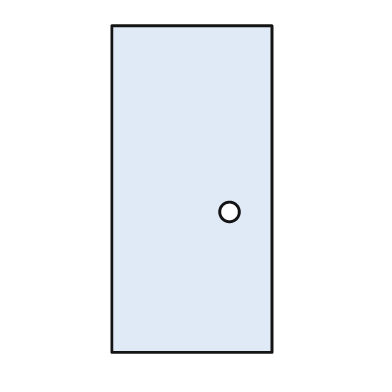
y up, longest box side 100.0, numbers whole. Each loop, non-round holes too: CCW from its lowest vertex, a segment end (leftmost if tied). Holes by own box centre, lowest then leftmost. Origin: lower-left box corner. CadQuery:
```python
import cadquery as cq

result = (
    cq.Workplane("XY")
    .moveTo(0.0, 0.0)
    .lineTo(49.0, 0.0)
    .lineTo(49.0, 100.0)
    .lineTo(0.0, 100.0)
    .close()
    .moveTo(36.0, 43.0)
    .circle(3.0)
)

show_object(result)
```